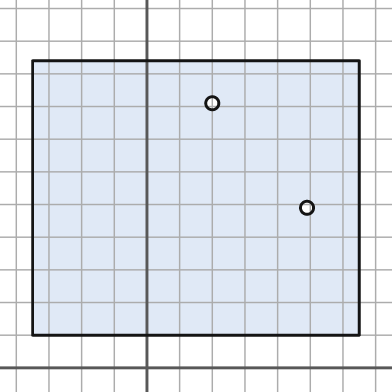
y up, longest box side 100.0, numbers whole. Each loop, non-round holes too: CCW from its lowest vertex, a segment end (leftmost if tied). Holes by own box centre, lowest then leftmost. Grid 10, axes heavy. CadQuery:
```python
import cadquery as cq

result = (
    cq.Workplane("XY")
    .moveTo(-35.0, 10.0)
    .lineTo(65.0, 10.0)
    .lineTo(65.0, 94.0)
    .lineTo(-35.0, 94.0)
    .close()
    .moveTo(49.0, 49.0)
    .circle(2.0)
    .moveTo(20.0, 81.0)
    .circle(2.0)
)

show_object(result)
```